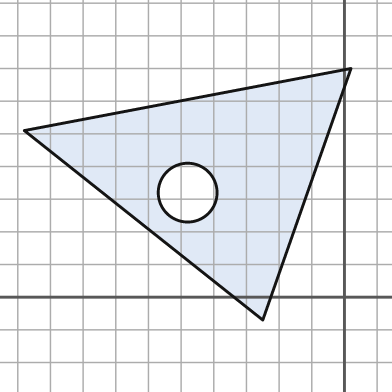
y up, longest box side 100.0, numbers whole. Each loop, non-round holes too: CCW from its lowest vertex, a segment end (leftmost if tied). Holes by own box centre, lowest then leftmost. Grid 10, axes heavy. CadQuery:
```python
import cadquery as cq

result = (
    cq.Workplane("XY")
    .moveTo(-25.0, -7.0)
    .lineTo(2.0, 70.0)
    .lineTo(-98.0, 51.0)
    .close()
    .moveTo(-48.0, 32.0)
    .circle(9.0)
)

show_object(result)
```